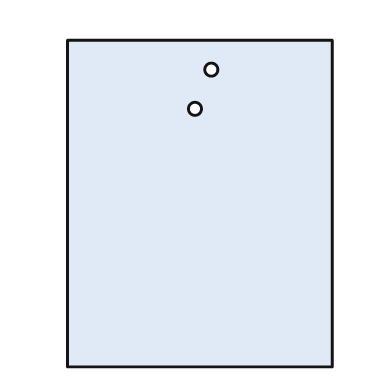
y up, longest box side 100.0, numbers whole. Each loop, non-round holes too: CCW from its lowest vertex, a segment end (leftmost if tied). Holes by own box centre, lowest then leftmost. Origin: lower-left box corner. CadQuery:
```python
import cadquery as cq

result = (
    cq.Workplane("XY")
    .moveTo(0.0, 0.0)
    .lineTo(81.0, 0.0)
    .lineTo(81.0, 100.0)
    .lineTo(0.0, 100.0)
    .close()
    .moveTo(39.0, 79.0)
    .circle(2.0)
    .moveTo(44.0, 91.0)
    .circle(2.0)
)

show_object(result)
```